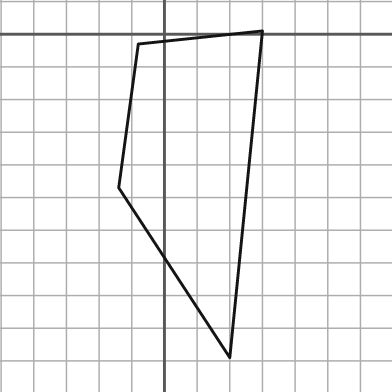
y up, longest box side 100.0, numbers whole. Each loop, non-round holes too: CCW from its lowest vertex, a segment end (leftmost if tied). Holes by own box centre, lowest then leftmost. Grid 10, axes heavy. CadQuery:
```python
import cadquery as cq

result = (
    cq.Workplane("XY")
    .moveTo(20.0, -99.0)
    .lineTo(30.0, 1.0)
    .lineTo(-8.0, -3.0)
    .lineTo(-14.0, -47.0)
    .close()
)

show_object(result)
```